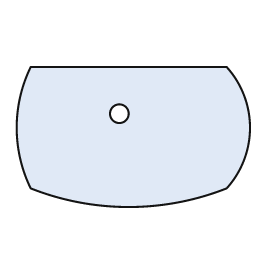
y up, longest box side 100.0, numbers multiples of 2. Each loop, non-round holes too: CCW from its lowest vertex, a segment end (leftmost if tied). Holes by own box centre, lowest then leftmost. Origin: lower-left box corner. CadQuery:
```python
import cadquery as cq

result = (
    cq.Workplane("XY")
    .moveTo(6.0, 8.0)
    .threePointArc((48.0, 0.0), (90.0, 8.0))
    .threePointArc((100.0, 34.0), (90.0, 60.0))
    .lineTo(6.0, 60.0)
    .threePointArc((0.0, 34.0), (6.0, 8.0))
    .close()
    .moveTo(44.0, 40.0)
    .circle(4.0)
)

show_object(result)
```